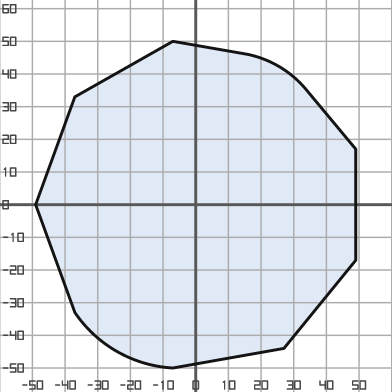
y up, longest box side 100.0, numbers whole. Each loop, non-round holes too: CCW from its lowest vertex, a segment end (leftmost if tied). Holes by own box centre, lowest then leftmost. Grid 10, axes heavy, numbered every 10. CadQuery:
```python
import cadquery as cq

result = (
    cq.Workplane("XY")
    .moveTo(-7.0, -50.0)
    .lineTo(27.0, -44.0)
    .lineTo(49.0, -17.0)
    .lineTo(49.0, 17.0)
    .lineTo(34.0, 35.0)
    .threePointArc((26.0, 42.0), (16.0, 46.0))
    .lineTo(-7.0, 50.0)
    .lineTo(-37.0, 33.0)
    .lineTo(-49.0, 0.0)
    .lineTo(-37.0, -33.0)
    .threePointArc((-24.0, -45.0), (-7.0, -50.0))
    .close()
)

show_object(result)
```